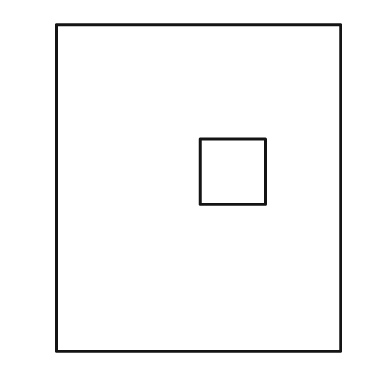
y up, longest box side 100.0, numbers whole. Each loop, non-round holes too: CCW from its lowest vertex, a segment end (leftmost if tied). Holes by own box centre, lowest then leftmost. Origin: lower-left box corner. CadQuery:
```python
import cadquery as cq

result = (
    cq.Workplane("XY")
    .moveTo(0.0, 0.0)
    .lineTo(87.0, 0.0)
    .lineTo(87.0, 100.0)
    .lineTo(0.0, 100.0)
    .close()
    .moveTo(44.0, 45.0)
    .lineTo(64.0, 45.0)
    .lineTo(64.0, 65.0)
    .lineTo(44.0, 65.0)
    .close()
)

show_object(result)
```